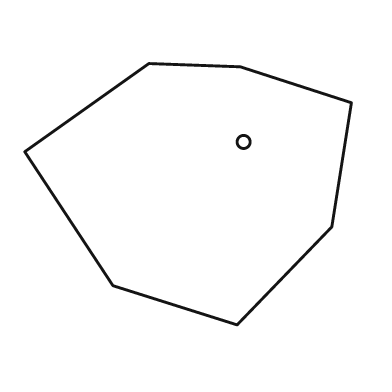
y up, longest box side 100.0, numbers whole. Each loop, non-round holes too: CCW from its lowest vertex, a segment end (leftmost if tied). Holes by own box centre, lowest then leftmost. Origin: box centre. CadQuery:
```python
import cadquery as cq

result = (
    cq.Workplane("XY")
    .moveTo(15.0, -40.0)
    .lineTo(44.0, -10.0)
    .lineTo(50.0, 28.0)
    .lineTo(16.0, 39.0)
    .lineTo(-12.0, 40.0)
    .lineTo(-50.0, 13.0)
    .lineTo(-23.0, -28.0)
    .close()
    .moveTo(17.0, 16.0)
    .circle(2.0)
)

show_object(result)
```